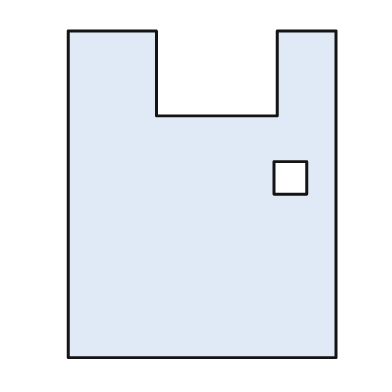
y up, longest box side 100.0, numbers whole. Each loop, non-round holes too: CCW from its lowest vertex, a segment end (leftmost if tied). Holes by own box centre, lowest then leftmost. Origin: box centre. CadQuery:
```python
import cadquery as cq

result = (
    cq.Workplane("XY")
    .moveTo(-41.0, -50.0)
    .lineTo(41.0, -50.0)
    .lineTo(41.0, 50.0)
    .lineTo(23.0, 50.0)
    .lineTo(23.0, 24.0)
    .lineTo(-14.0, 24.0)
    .lineTo(-14.0, 50.0)
    .lineTo(-41.0, 50.0)
    .close()
    .moveTo(22.0, 0.0)
    .lineTo(32.0, 0.0)
    .lineTo(32.0, 10.0)
    .lineTo(22.0, 10.0)
    .close()
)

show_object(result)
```